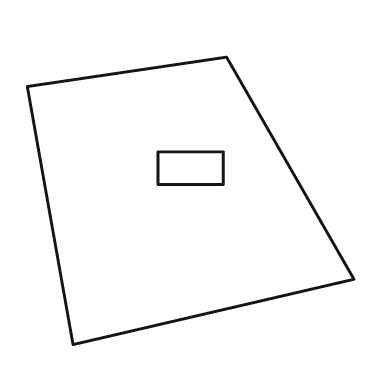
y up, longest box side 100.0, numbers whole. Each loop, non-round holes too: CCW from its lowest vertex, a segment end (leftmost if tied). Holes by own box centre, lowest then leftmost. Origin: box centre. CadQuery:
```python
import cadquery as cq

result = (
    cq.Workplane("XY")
    .moveTo(-36.0, -44.0)
    .lineTo(50.0, -24.0)
    .lineTo(11.0, 44.0)
    .lineTo(-50.0, 35.0)
    .close()
    .moveTo(-10.0, 5.0)
    .lineTo(10.0, 5.0)
    .lineTo(10.0, 15.0)
    .lineTo(-10.0, 15.0)
    .close()
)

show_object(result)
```